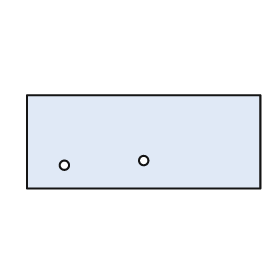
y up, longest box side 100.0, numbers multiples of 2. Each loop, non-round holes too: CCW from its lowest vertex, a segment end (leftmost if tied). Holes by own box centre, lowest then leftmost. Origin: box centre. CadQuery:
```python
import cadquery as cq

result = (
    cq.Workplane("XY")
    .moveTo(-50.0, -20.0)
    .lineTo(50.0, -20.0)
    .lineTo(50.0, 20.0)
    .lineTo(-50.0, 20.0)
    .close()
    .moveTo(-34.0, -10.0)
    .circle(2.0)
    .moveTo(0.0, -8.0)
    .circle(2.0)
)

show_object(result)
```